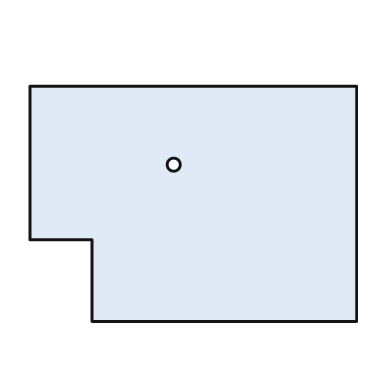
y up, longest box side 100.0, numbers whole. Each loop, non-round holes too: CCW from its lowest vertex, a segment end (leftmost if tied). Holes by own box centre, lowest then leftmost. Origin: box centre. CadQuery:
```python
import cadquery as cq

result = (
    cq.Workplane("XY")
    .moveTo(-31.0, -36.0)
    .lineTo(50.0, -36.0)
    .lineTo(50.0, 36.0)
    .lineTo(-50.0, 36.0)
    .lineTo(-50.0, -11.0)
    .lineTo(-31.0, -11.0)
    .close()
    .moveTo(-6.0, 12.0)
    .circle(2.0)
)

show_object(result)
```